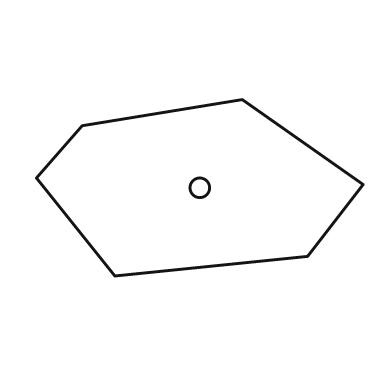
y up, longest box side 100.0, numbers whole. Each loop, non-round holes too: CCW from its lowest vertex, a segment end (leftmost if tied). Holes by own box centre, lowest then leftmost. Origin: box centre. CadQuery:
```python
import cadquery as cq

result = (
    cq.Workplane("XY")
    .moveTo(-26.0, -27.0)
    .lineTo(33.0, -21.0)
    .lineTo(50.0, 1.0)
    .lineTo(13.0, 27.0)
    .lineTo(-36.0, 19.0)
    .lineTo(-50.0, 3.0)
    .close()
    .moveTo(0.0, 0.0)
    .circle(3.0)
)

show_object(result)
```